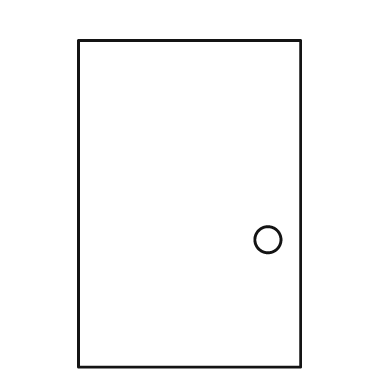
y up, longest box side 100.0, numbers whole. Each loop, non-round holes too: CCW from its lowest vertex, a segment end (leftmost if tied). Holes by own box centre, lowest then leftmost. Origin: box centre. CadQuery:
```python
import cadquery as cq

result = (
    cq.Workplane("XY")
    .moveTo(-34.0, -50.0)
    .lineTo(34.0, -50.0)
    .lineTo(34.0, 50.0)
    .lineTo(-34.0, 50.0)
    .close()
    .moveTo(24.0, -11.0)
    .circle(4.0)
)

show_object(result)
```